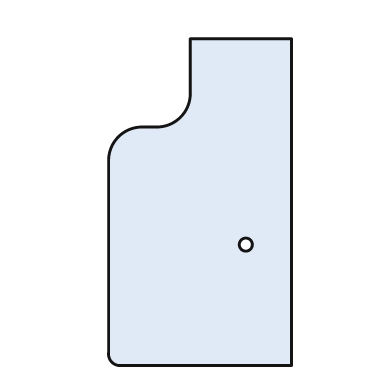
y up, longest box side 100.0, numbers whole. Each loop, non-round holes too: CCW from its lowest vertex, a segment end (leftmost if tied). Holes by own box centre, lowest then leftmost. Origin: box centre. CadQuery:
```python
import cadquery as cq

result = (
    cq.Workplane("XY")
    .moveTo(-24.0, -50.0)
    .lineTo(28.0, -50.0)
    .lineTo(28.0, 50.0)
    .lineTo(-3.0, 50.0)
    .lineTo(-3.0, 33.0)
    .threePointArc((-6.0, 26.0), (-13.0, 23.0))
    .lineTo(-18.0, 23.0)
    .threePointArc((-25.0, 20.0), (-28.0, 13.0))
    .lineTo(-28.0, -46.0)
    .threePointArc((-27.0, -49.0), (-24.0, -50.0))
    .close()
    .moveTo(14.0, -13.0)
    .circle(2.0)
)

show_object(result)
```